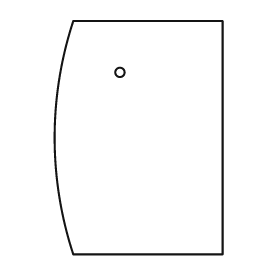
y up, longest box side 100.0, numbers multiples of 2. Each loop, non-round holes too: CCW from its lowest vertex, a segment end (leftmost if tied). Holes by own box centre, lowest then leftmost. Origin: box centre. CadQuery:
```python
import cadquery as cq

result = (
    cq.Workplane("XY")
    .moveTo(-28.0, -50.0)
    .lineTo(36.0, -50.0)
    .lineTo(36.0, 50.0)
    .lineTo(-28.0, 50.0)
    .threePointArc((-36.0, 0.0), (-28.0, -50.0))
    .close()
    .moveTo(-8.0, 28.0)
    .circle(2.0)
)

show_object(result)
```